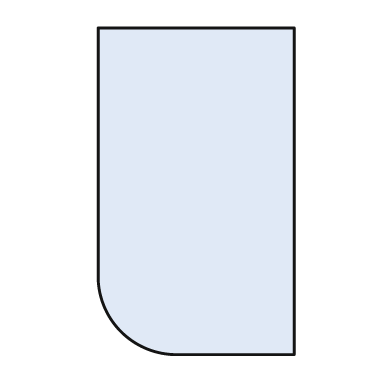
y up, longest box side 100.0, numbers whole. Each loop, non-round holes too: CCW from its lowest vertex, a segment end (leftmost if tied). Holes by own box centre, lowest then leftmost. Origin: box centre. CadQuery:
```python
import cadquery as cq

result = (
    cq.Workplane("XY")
    .moveTo(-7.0, -50.0)
    .lineTo(30.0, -50.0)
    .lineTo(30.0, 50.0)
    .lineTo(-30.0, 50.0)
    .lineTo(-30.0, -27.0)
    .threePointArc((-23.0, -43.0), (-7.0, -50.0))
    .close()
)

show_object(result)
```